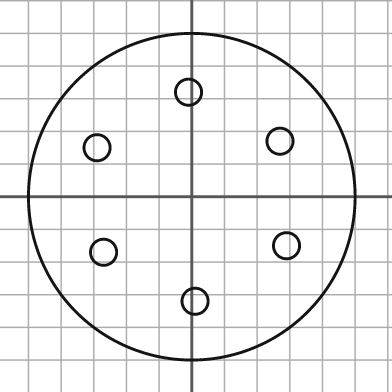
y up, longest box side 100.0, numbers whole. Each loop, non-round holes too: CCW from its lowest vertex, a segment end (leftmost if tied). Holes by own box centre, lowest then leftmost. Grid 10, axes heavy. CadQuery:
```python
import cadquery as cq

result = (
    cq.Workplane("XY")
    .moveTo(0.0, 0.0)
    .circle(50.0)
    .moveTo(1.0, -32.0)
    .circle(4.0)
    .moveTo(-27.0, -17.0)
    .circle(4.0)
    .moveTo(29.0, -15.0)
    .circle(4.0)
    .moveTo(-29.0, 15.0)
    .circle(4.0)
    .moveTo(27.0, 17.0)
    .circle(4.0)
    .moveTo(-1.0, 32.0)
    .circle(4.0)
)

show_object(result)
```